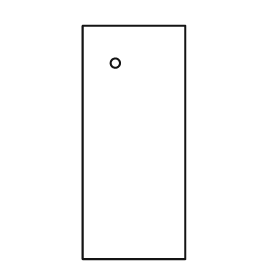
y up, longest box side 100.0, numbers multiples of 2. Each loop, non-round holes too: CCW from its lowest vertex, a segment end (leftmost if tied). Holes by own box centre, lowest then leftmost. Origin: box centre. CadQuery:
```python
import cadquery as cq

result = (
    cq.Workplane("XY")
    .moveTo(-22.0, -50.0)
    .lineTo(22.0, -50.0)
    .lineTo(22.0, 50.0)
    .lineTo(-22.0, 50.0)
    .close()
    .moveTo(-8.0, 34.0)
    .circle(2.0)
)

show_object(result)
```